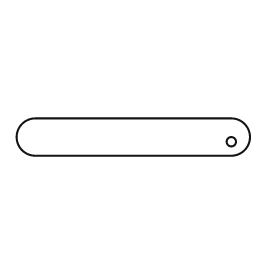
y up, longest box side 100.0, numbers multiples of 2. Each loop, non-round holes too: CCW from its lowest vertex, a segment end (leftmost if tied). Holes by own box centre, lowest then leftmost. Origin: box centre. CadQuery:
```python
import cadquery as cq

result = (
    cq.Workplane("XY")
    .moveTo(-42.0, -8.0)
    .lineTo(42.0, -8.0)
    .threePointArc((50.0, 0.0), (42.0, 8.0))
    .lineTo(-42.0, 8.0)
    .threePointArc((-50.0, 0.0), (-42.0, -8.0))
    .close()
    .moveTo(42.0, -2.0)
    .circle(2.0)
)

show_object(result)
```